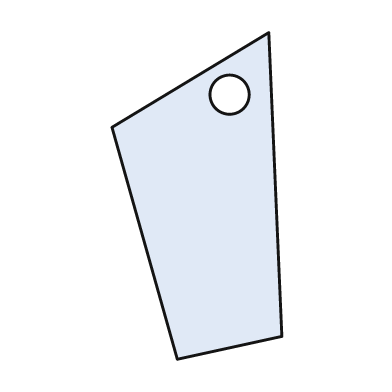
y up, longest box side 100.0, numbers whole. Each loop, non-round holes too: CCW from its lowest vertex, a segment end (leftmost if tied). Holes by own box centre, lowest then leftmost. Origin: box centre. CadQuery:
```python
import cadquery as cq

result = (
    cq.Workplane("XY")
    .moveTo(-6.0, -50.0)
    .lineTo(26.0, -43.0)
    .lineTo(22.0, 50.0)
    .lineTo(-26.0, 21.0)
    .close()
    .moveTo(10.0, 31.0)
    .circle(6.0)
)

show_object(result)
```